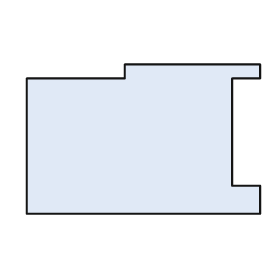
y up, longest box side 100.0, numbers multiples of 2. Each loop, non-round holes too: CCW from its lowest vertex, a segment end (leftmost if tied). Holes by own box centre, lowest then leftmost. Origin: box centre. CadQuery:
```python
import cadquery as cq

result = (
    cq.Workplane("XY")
    .moveTo(-50.0, -32.0)
    .lineTo(50.0, -32.0)
    .lineTo(50.0, -20.0)
    .lineTo(38.0, -20.0)
    .lineTo(38.0, 26.0)
    .lineTo(50.0, 26.0)
    .lineTo(50.0, 32.0)
    .lineTo(-8.0, 32.0)
    .lineTo(-8.0, 26.0)
    .lineTo(-50.0, 26.0)
    .close()
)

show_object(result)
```